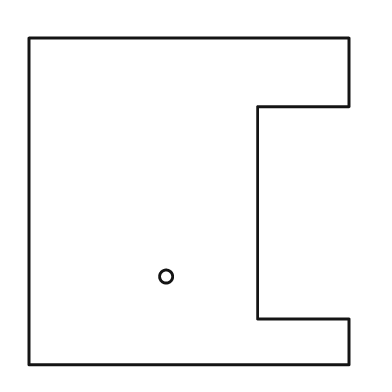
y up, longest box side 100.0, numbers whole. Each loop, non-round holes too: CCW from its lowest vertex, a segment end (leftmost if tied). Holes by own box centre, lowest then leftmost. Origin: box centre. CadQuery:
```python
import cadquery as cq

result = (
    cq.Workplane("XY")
    .moveTo(-49.0, -50.0)
    .lineTo(49.0, -50.0)
    .lineTo(49.0, -36.0)
    .lineTo(21.0, -36.0)
    .lineTo(21.0, 29.0)
    .lineTo(49.0, 29.0)
    .lineTo(49.0, 50.0)
    .lineTo(-49.0, 50.0)
    .close()
    .moveTo(-7.0, -23.0)
    .circle(2.0)
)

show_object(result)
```